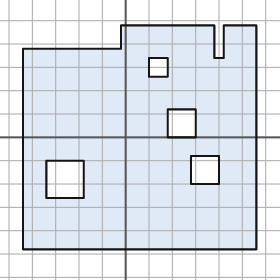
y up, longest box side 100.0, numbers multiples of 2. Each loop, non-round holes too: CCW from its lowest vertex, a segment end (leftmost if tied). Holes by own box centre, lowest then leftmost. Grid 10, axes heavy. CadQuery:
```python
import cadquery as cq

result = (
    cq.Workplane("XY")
    .moveTo(-44.0, -48.0)
    .lineTo(56.0, -48.0)
    .lineTo(56.0, 48.0)
    .lineTo(42.0, 48.0)
    .lineTo(42.0, 34.0)
    .lineTo(38.0, 34.0)
    .lineTo(38.0, 48.0)
    .lineTo(-2.0, 48.0)
    .lineTo(-2.0, 38.0)
    .lineTo(-44.0, 38.0)
    .close()
    .moveTo(-34.0, -26.0)
    .lineTo(-18.0, -26.0)
    .lineTo(-18.0, -10.0)
    .lineTo(-34.0, -10.0)
    .close()
    .moveTo(28.0, -20.0)
    .lineTo(40.0, -20.0)
    .lineTo(40.0, -8.0)
    .lineTo(28.0, -8.0)
    .close()
    .moveTo(18.0, 0.0)
    .lineTo(30.0, 0.0)
    .lineTo(30.0, 12.0)
    .lineTo(18.0, 12.0)
    .close()
    .moveTo(10.0, 26.0)
    .lineTo(18.0, 26.0)
    .lineTo(18.0, 34.0)
    .lineTo(10.0, 34.0)
    .close()
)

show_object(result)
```